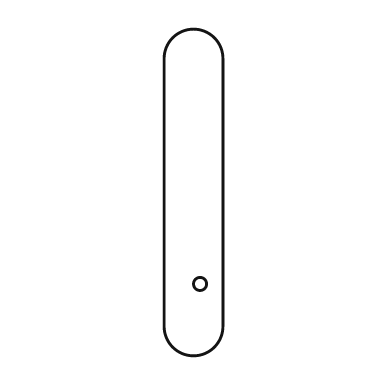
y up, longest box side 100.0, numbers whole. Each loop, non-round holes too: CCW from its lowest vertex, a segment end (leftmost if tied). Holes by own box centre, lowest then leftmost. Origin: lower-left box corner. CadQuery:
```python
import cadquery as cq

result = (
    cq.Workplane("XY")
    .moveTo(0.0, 9.0)
    .threePointArc((9.0, 0.0), (18.0, 9.0))
    .lineTo(18.0, 91.0)
    .threePointArc((9.0, 100.0), (0.0, 91.0))
    .close()
    .moveTo(11.0, 22.0)
    .circle(2.0)
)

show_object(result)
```